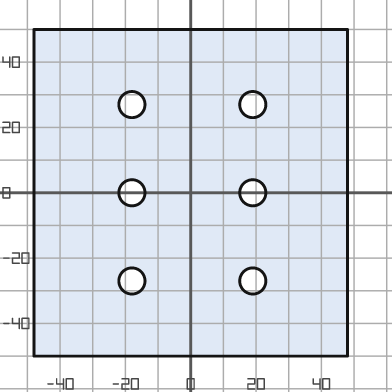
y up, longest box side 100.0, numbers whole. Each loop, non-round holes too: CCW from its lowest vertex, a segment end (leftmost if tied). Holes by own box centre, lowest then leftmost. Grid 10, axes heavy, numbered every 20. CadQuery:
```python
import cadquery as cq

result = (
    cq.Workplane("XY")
    .moveTo(-48.0, -50.0)
    .lineTo(48.0, -50.0)
    .lineTo(48.0, 50.0)
    .lineTo(-48.0, 50.0)
    .close()
    .moveTo(-18.0, -27.0)
    .circle(4.0)
    .moveTo(19.0, -27.0)
    .circle(4.0)
    .moveTo(-18.0, 0.0)
    .circle(4.0)
    .moveTo(19.0, 0.0)
    .circle(4.0)
    .moveTo(-18.0, 27.0)
    .circle(4.0)
    .moveTo(19.0, 27.0)
    .circle(4.0)
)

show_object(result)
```